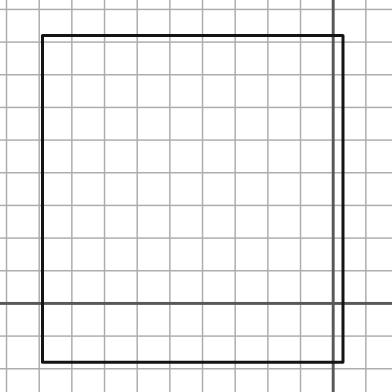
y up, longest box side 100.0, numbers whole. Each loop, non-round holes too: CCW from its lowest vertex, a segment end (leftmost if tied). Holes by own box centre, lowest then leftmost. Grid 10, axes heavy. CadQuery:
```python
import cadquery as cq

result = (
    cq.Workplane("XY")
    .moveTo(-89.0, -18.0)
    .lineTo(3.0, -18.0)
    .lineTo(3.0, 82.0)
    .lineTo(-89.0, 82.0)
    .close()
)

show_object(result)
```